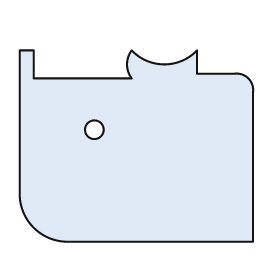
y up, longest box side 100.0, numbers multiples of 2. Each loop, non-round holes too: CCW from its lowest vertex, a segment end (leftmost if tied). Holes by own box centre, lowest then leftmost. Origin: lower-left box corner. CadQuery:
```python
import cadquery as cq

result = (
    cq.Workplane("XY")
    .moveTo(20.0, 0.0)
    .lineTo(100.0, 0.0)
    .lineTo(100.0, 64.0)
    .threePointArc((98.0, 70.0), (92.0, 72.0))
    .lineTo(76.0, 72.0)
    .lineTo(76.0, 82.0)
    .threePointArc((62.0, 76.0), (48.0, 82.0))
    .threePointArc((46.0, 76.0), (48.0, 70.0))
    .lineTo(6.0, 70.0)
    .lineTo(6.0, 82.0)
    .lineTo(0.0, 82.0)
    .lineTo(0.0, 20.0)
    .threePointArc((6.0, 6.0), (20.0, 0.0))
    .close()
    .moveTo(32.0, 48.0)
    .circle(4.0)
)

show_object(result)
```